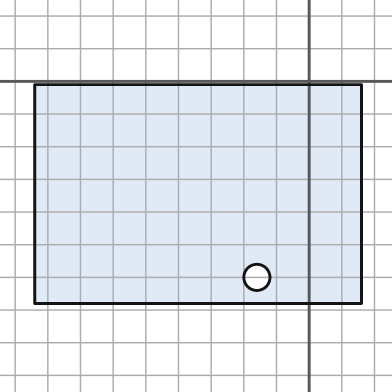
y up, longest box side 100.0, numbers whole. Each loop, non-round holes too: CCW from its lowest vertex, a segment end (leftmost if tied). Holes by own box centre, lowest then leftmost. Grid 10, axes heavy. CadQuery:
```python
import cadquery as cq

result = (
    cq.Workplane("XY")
    .moveTo(-84.0, -68.0)
    .lineTo(16.0, -68.0)
    .lineTo(16.0, -1.0)
    .lineTo(-84.0, -1.0)
    .close()
    .moveTo(-16.0, -60.0)
    .circle(4.0)
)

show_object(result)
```